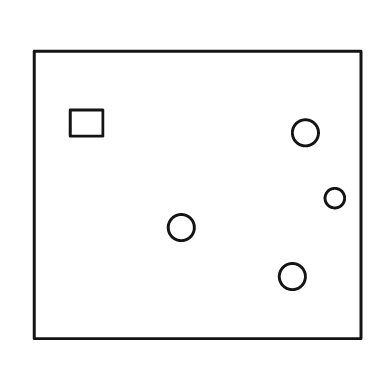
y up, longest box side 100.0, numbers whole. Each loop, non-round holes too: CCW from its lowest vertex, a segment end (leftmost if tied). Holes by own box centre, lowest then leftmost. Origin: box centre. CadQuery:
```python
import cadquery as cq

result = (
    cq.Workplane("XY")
    .moveTo(-50.0, -44.0)
    .lineTo(50.0, -44.0)
    .lineTo(50.0, 44.0)
    .lineTo(-50.0, 44.0)
    .close()
    .moveTo(29.0, -25.0)
    .circle(4.0)
    .moveTo(-5.0, -10.0)
    .circle(4.0)
    .moveTo(42.0, -1.0)
    .circle(3.0)
    .moveTo(33.0, 19.0)
    .circle(4.0)
    .moveTo(-39.0, 18.0)
    .lineTo(-29.0, 18.0)
    .lineTo(-29.0, 26.0)
    .lineTo(-39.0, 26.0)
    .close()
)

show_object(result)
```